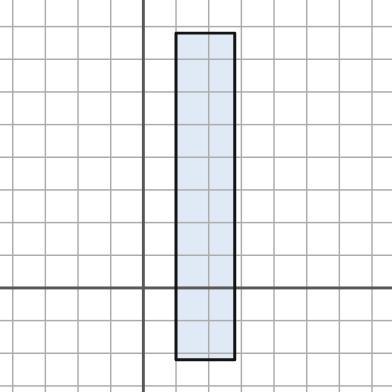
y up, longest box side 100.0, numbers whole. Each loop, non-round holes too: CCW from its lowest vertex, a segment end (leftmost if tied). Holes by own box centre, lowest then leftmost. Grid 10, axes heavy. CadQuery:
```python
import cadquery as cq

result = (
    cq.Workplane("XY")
    .moveTo(10.0, -22.0)
    .lineTo(28.0, -22.0)
    .lineTo(28.0, 78.0)
    .lineTo(10.0, 78.0)
    .close()
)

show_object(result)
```